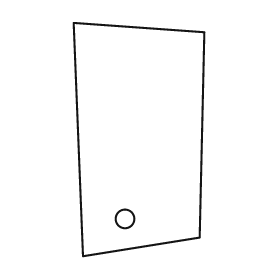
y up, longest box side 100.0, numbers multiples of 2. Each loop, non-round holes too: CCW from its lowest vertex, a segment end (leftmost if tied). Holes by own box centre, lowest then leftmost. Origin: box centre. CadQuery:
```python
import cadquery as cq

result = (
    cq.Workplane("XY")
    .moveTo(-24.0, -50.0)
    .lineTo(26.0, -42.0)
    .lineTo(28.0, 46.0)
    .lineTo(-28.0, 50.0)
    .close()
    .moveTo(-6.0, -34.0)
    .circle(4.0)
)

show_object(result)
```